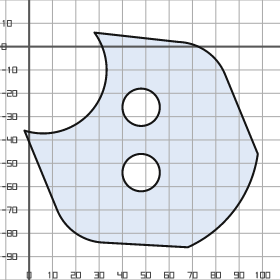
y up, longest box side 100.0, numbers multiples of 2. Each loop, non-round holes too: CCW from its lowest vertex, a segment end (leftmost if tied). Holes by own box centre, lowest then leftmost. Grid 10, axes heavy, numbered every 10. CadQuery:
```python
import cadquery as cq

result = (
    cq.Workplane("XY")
    .moveTo(68.0, -86.0)
    .threePointArc((88.0, -70.0), (98.0, -46.0))
    .lineTo(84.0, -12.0)
    .threePointArc((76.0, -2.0), (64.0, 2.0))
    .lineTo(28.0, 6.0)
    .threePointArc((28.0, -26.0), (-2.0, -36.0))
    .lineTo(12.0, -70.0)
    .threePointArc((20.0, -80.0), (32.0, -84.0))
    .close()
    .moveTo(48.0, -54.0)
    .circle(8.0)
    .moveTo(48.0, -26.0)
    .circle(8.0)
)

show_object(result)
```